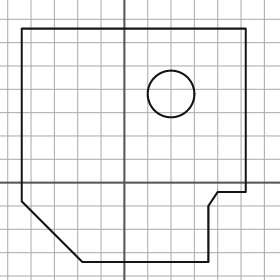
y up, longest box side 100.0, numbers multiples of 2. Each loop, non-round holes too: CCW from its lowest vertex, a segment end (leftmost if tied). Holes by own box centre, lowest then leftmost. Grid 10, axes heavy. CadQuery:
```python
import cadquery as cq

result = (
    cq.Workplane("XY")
    .moveTo(-18.0, -34.0)
    .lineTo(36.0, -34.0)
    .lineTo(36.0, -10.0)
    .lineTo(40.0, -4.0)
    .lineTo(52.0, -4.0)
    .lineTo(52.0, 66.0)
    .lineTo(-44.0, 66.0)
    .lineTo(-44.0, -8.0)
    .close()
    .moveTo(20.0, 38.0)
    .circle(10.0)
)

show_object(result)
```